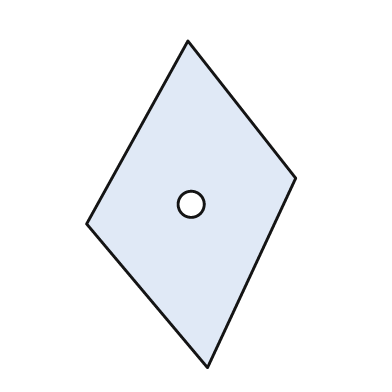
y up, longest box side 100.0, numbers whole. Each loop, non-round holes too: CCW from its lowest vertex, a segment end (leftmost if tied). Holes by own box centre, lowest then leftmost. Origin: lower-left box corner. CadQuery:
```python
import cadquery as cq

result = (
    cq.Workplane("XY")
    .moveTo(37.0, 0.0)
    .lineTo(64.0, 58.0)
    .lineTo(31.0, 100.0)
    .lineTo(0.0, 44.0)
    .close()
    .moveTo(32.0, 50.0)
    .circle(4.0)
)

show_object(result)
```